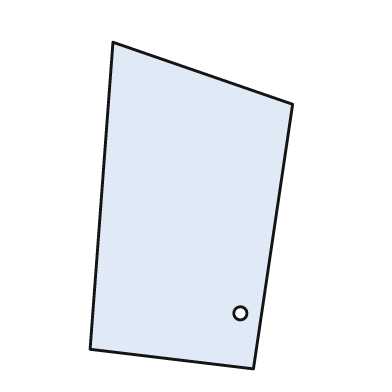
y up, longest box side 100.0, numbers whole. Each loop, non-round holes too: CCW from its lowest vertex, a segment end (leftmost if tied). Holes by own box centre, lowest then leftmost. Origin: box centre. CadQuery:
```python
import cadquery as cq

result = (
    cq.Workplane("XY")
    .moveTo(19.0, -50.0)
    .lineTo(31.0, 31.0)
    .lineTo(-24.0, 50.0)
    .lineTo(-31.0, -44.0)
    .close()
    .moveTo(15.0, -33.0)
    .circle(2.0)
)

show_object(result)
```